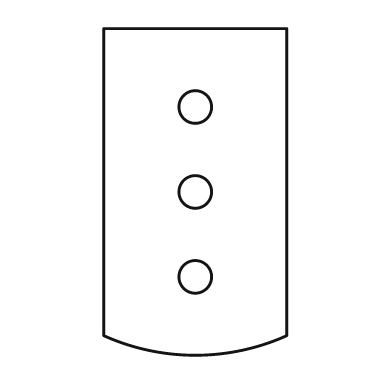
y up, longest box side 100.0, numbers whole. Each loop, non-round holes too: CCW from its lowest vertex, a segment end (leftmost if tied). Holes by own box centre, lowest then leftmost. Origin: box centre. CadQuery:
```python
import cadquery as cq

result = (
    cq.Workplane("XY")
    .moveTo(-28.0, -44.0)
    .threePointArc((0.0, -50.0), (28.0, -44.0))
    .lineTo(28.0, 50.0)
    .lineTo(-28.0, 50.0)
    .close()
    .moveTo(0.0, -26.0)
    .circle(5.0)
    .moveTo(0.0, 0.0)
    .circle(5.0)
    .moveTo(0.0, 26.0)
    .circle(5.0)
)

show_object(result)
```